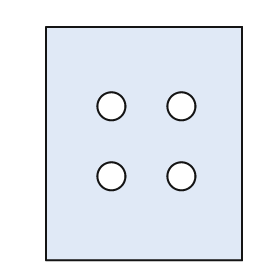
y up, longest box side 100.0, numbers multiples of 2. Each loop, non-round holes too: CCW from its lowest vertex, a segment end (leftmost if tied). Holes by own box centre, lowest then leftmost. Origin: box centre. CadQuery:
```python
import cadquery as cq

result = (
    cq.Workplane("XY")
    .moveTo(-42.0, -50.0)
    .lineTo(42.0, -50.0)
    .lineTo(42.0, 50.0)
    .lineTo(-42.0, 50.0)
    .close()
    .moveTo(-14.0, -14.0)
    .circle(6.0)
    .moveTo(16.0, -14.0)
    .circle(6.0)
    .moveTo(-14.0, 16.0)
    .circle(6.0)
    .moveTo(16.0, 16.0)
    .circle(6.0)
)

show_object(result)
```